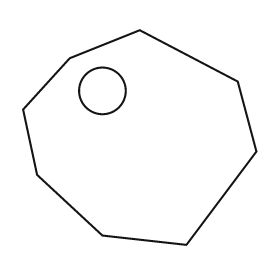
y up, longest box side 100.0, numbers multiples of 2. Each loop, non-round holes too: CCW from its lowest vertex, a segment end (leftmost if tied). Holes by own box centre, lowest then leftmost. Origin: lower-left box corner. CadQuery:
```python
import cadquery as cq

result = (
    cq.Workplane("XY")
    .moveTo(70.0, 0.0)
    .lineTo(100.0, 40.0)
    .lineTo(92.0, 70.0)
    .lineTo(50.0, 92.0)
    .lineTo(20.0, 80.0)
    .lineTo(0.0, 58.0)
    .lineTo(6.0, 30.0)
    .lineTo(34.0, 4.0)
    .close()
    .moveTo(34.0, 66.0)
    .circle(10.0)
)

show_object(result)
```